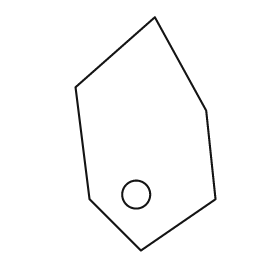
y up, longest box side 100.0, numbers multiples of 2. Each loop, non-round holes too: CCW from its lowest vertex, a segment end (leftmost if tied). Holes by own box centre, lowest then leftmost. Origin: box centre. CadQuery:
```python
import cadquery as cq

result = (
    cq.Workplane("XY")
    .moveTo(-2.0, -50.0)
    .lineTo(30.0, -28.0)
    .lineTo(26.0, 10.0)
    .lineTo(4.0, 50.0)
    .lineTo(-30.0, 20.0)
    .lineTo(-24.0, -28.0)
    .close()
    .moveTo(-4.0, -26.0)
    .circle(6.0)
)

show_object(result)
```